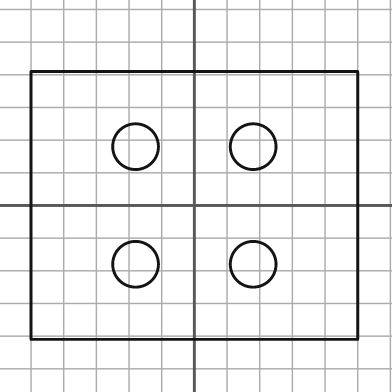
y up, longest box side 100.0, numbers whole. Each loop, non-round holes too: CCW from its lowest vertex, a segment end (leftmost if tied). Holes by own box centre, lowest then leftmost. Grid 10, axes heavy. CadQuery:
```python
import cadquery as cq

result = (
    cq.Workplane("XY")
    .moveTo(-50.0, -41.0)
    .lineTo(50.0, -41.0)
    .lineTo(50.0, 41.0)
    .lineTo(-50.0, 41.0)
    .close()
    .moveTo(-18.0, -18.0)
    .circle(7.0)
    .moveTo(18.0, -18.0)
    .circle(7.0)
    .moveTo(-18.0, 18.0)
    .circle(7.0)
    .moveTo(18.0, 18.0)
    .circle(7.0)
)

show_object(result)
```